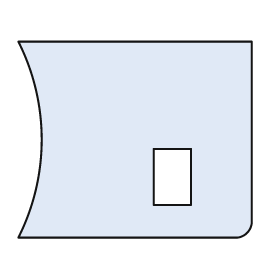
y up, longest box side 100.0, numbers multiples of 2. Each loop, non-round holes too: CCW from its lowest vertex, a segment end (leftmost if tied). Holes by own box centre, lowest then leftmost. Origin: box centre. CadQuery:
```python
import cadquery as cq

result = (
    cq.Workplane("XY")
    .moveTo(-50.0, -42.0)
    .lineTo(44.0, -42.0)
    .threePointArc((48.0, -40.0), (50.0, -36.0))
    .lineTo(50.0, 42.0)
    .lineTo(-50.0, 42.0)
    .threePointArc((-40.0, 0.0), (-50.0, -42.0))
    .close()
    .moveTo(8.0, -28.0)
    .lineTo(24.0, -28.0)
    .lineTo(24.0, -4.0)
    .lineTo(8.0, -4.0)
    .close()
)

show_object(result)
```